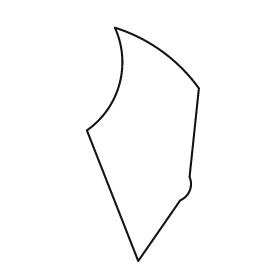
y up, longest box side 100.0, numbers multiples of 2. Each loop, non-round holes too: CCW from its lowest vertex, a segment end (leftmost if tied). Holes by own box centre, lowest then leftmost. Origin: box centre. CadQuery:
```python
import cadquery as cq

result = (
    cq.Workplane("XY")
    .moveTo(-2.0, -50.0)
    .lineTo(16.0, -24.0)
    .threePointArc((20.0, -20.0), (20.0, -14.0))
    .lineTo(24.0, 24.0)
    .threePointArc((8.0, 40.0), (-12.0, 50.0))
    .threePointArc((-10.0, 26.0), (-24.0, 6.0))
    .close()
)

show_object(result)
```